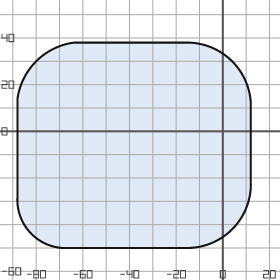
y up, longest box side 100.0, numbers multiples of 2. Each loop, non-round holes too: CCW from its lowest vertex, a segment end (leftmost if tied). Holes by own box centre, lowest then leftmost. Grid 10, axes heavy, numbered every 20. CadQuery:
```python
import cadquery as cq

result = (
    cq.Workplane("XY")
    .moveTo(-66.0, -50.0)
    .lineTo(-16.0, -50.0)
    .threePointArc((4.0, -42.0), (12.0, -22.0))
    .lineTo(12.0, 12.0)
    .threePointArc((4.0, 30.0), (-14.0, 38.0))
    .lineTo(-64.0, 38.0)
    .threePointArc((-80.0, 30.0), (-88.0, 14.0))
    .lineTo(-88.0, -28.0)
    .threePointArc((-82.0, -44.0), (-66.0, -50.0))
    .close()
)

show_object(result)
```